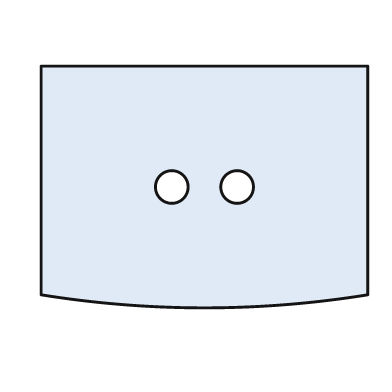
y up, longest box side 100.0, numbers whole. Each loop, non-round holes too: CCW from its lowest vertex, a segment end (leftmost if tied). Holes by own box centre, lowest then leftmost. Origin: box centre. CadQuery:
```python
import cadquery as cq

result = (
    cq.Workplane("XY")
    .moveTo(-50.0, -33.0)
    .threePointArc((0.0, -37.0), (50.0, -33.0))
    .lineTo(50.0, 37.0)
    .lineTo(-50.0, 37.0)
    .close()
    .moveTo(-10.0, 0.0)
    .circle(5.0)
    .moveTo(10.0, 0.0)
    .circle(5.0)
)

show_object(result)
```